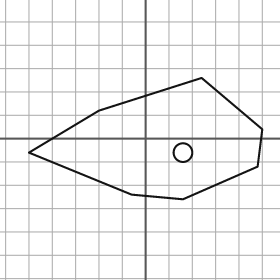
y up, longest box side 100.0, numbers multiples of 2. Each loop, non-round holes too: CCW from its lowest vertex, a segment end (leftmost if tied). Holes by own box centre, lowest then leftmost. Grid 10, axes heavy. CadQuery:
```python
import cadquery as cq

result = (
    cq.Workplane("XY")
    .moveTo(16.0, -26.0)
    .lineTo(48.0, -12.0)
    .lineTo(50.0, 4.0)
    .lineTo(24.0, 26.0)
    .lineTo(-20.0, 12.0)
    .lineTo(-50.0, -6.0)
    .lineTo(-6.0, -24.0)
    .close()
    .moveTo(16.0, -6.0)
    .circle(4.0)
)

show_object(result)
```